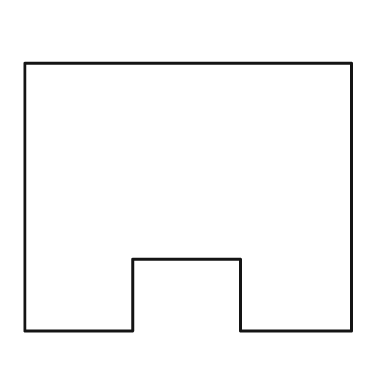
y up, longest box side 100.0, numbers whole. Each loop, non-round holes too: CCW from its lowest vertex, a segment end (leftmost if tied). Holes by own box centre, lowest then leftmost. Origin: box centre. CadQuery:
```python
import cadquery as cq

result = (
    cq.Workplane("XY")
    .moveTo(-50.0, -41.0)
    .lineTo(-17.0, -41.0)
    .lineTo(-17.0, -19.0)
    .lineTo(16.0, -19.0)
    .lineTo(16.0, -41.0)
    .lineTo(50.0, -41.0)
    .lineTo(50.0, 41.0)
    .lineTo(-50.0, 41.0)
    .close()
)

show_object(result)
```